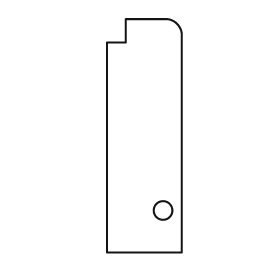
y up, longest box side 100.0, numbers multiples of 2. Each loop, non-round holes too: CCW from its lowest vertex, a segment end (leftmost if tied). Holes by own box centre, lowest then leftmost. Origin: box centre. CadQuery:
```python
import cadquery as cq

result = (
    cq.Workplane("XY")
    .moveTo(-16.0, -50.0)
    .lineTo(16.0, -50.0)
    .lineTo(16.0, 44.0)
    .threePointArc((14.0, 48.0), (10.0, 50.0))
    .lineTo(-8.0, 50.0)
    .lineTo(-8.0, 40.0)
    .lineTo(-16.0, 40.0)
    .close()
    .moveTo(8.0, -32.0)
    .circle(4.0)
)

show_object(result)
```